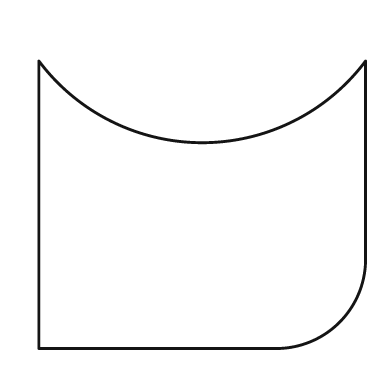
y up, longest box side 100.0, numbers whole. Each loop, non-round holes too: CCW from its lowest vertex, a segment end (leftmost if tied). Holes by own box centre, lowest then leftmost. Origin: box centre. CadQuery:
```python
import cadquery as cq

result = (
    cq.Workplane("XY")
    .moveTo(-50.0, -44.0)
    .lineTo(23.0, -44.0)
    .threePointArc((42.0, -36.0), (50.0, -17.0))
    .lineTo(50.0, 44.0)
    .threePointArc((0.0, 19.0), (-50.0, 44.0))
    .close()
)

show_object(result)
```